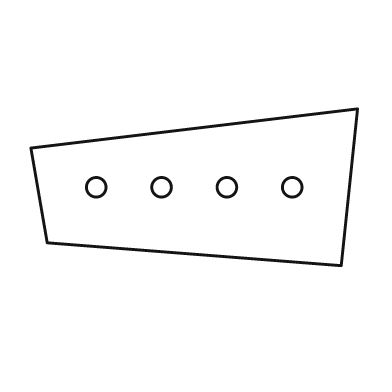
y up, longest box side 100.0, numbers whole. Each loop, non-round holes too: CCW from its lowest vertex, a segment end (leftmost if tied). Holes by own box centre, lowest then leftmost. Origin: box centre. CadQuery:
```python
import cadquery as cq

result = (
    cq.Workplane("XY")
    .moveTo(45.0, -24.0)
    .lineTo(50.0, 24.0)
    .lineTo(-50.0, 12.0)
    .lineTo(-45.0, -17.0)
    .close()
    .moveTo(-30.0, 0.0)
    .circle(3.0)
    .moveTo(-10.0, 0.0)
    .circle(3.0)
    .moveTo(10.0, 0.0)
    .circle(3.0)
    .moveTo(30.0, 0.0)
    .circle(3.0)
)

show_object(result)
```